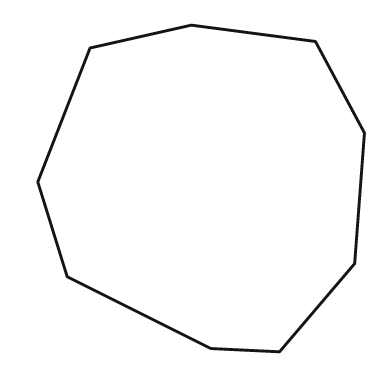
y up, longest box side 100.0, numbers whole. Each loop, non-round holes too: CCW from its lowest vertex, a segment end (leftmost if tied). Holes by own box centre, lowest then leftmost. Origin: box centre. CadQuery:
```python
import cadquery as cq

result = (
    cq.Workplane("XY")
    .moveTo(24.0, -50.0)
    .lineTo(47.0, -23.0)
    .lineTo(50.0, 17.0)
    .lineTo(35.0, 45.0)
    .lineTo(-3.0, 50.0)
    .lineTo(-34.0, 43.0)
    .lineTo(-50.0, 2.0)
    .lineTo(-41.0, -27.0)
    .lineTo(3.0, -49.0)
    .close()
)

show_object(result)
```